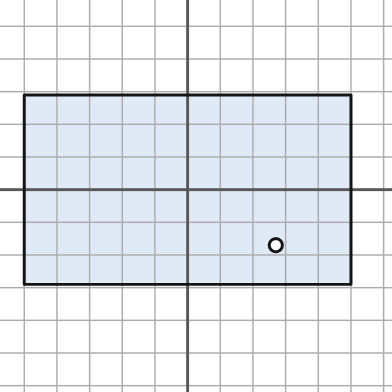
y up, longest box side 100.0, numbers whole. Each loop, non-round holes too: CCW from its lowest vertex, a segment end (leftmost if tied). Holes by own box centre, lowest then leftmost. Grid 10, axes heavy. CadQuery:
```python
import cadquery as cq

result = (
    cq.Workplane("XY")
    .moveTo(-50.0, -29.0)
    .lineTo(50.0, -29.0)
    .lineTo(50.0, 29.0)
    .lineTo(-50.0, 29.0)
    .close()
    .moveTo(27.0, -17.0)
    .circle(2.0)
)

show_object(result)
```